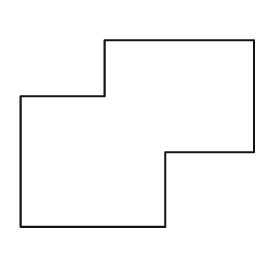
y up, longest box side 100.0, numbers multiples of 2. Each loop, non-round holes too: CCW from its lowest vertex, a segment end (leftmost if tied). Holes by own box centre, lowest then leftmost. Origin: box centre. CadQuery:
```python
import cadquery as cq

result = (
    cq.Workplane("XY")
    .moveTo(-50.0, -40.0)
    .lineTo(12.0, -40.0)
    .lineTo(12.0, -8.0)
    .lineTo(50.0, -8.0)
    .lineTo(50.0, 40.0)
    .lineTo(-14.0, 40.0)
    .lineTo(-14.0, 16.0)
    .lineTo(-50.0, 16.0)
    .close()
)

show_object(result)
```